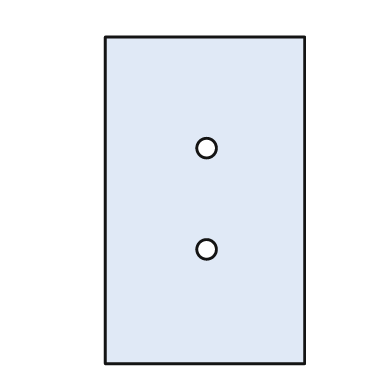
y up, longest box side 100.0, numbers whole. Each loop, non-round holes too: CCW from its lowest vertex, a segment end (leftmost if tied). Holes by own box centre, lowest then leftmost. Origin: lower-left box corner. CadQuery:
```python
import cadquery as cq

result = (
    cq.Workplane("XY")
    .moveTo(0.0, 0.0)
    .lineTo(61.0, 0.0)
    .lineTo(61.0, 100.0)
    .lineTo(0.0, 100.0)
    .close()
    .moveTo(31.0, 35.0)
    .circle(3.0)
    .moveTo(31.0, 66.0)
    .circle(3.0)
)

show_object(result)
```